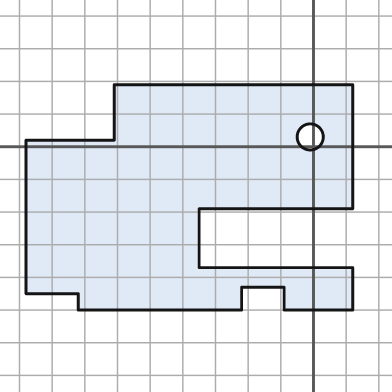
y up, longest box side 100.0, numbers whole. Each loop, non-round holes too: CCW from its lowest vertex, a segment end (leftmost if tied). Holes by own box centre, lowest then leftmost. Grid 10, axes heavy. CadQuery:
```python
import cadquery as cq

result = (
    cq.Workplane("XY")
    .moveTo(-72.0, -50.0)
    .lineTo(-22.0, -50.0)
    .lineTo(-22.0, -43.0)
    .lineTo(-9.0, -43.0)
    .lineTo(-9.0, -50.0)
    .lineTo(12.0, -50.0)
    .lineTo(12.0, -37.0)
    .lineTo(-35.0, -37.0)
    .lineTo(-35.0, -19.0)
    .lineTo(12.0, -19.0)
    .lineTo(12.0, 19.0)
    .lineTo(-61.0, 19.0)
    .lineTo(-61.0, 2.0)
    .lineTo(-88.0, 2.0)
    .lineTo(-88.0, -45.0)
    .lineTo(-72.0, -45.0)
    .close()
    .moveTo(-1.0, 3.0)
    .circle(4.0)
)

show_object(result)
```